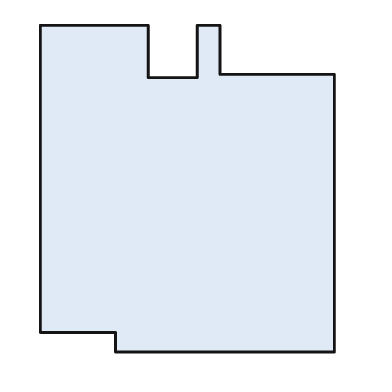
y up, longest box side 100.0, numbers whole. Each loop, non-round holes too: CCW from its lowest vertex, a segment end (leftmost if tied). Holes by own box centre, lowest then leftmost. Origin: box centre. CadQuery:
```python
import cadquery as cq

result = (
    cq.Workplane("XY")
    .moveTo(-22.0, -50.0)
    .lineTo(45.0, -50.0)
    .lineTo(45.0, 35.0)
    .lineTo(10.0, 35.0)
    .lineTo(10.0, 50.0)
    .lineTo(3.0, 50.0)
    .lineTo(3.0, 34.0)
    .lineTo(-12.0, 34.0)
    .lineTo(-12.0, 50.0)
    .lineTo(-45.0, 50.0)
    .lineTo(-45.0, -44.0)
    .lineTo(-22.0, -44.0)
    .close()
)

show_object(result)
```